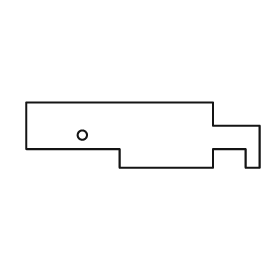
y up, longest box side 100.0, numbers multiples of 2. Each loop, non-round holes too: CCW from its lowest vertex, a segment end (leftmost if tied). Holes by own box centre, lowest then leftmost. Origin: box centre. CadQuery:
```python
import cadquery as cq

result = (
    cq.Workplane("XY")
    .moveTo(-10.0, -14.0)
    .lineTo(30.0, -14.0)
    .lineTo(30.0, -6.0)
    .lineTo(44.0, -6.0)
    .lineTo(44.0, -14.0)
    .lineTo(50.0, -14.0)
    .lineTo(50.0, 4.0)
    .lineTo(30.0, 4.0)
    .lineTo(30.0, 14.0)
    .lineTo(-50.0, 14.0)
    .lineTo(-50.0, -6.0)
    .lineTo(-10.0, -6.0)
    .close()
    .moveTo(-26.0, 0.0)
    .circle(2.0)
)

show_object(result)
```